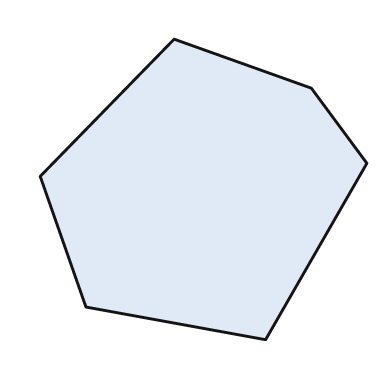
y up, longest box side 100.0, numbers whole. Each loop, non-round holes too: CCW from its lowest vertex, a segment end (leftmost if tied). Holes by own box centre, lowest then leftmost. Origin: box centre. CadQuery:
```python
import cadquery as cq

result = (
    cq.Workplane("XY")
    .moveTo(19.0, -46.0)
    .lineTo(50.0, 8.0)
    .lineTo(33.0, 31.0)
    .lineTo(-9.0, 46.0)
    .lineTo(-50.0, 4.0)
    .lineTo(-36.0, -36.0)
    .close()
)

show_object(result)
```